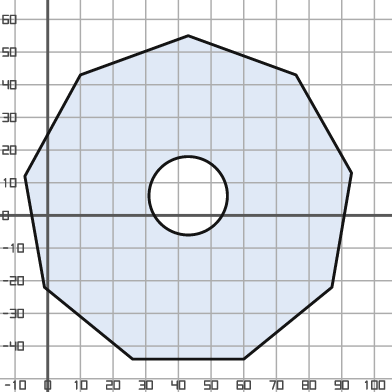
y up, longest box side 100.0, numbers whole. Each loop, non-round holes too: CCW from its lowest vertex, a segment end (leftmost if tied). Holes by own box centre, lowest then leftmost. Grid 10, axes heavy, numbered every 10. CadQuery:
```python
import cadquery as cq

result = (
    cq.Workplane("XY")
    .moveTo(26.0, -44.0)
    .lineTo(60.0, -44.0)
    .lineTo(87.0, -22.0)
    .lineTo(93.0, 13.0)
    .lineTo(76.0, 43.0)
    .lineTo(43.0, 55.0)
    .lineTo(10.0, 43.0)
    .lineTo(-7.0, 12.0)
    .lineTo(-1.0, -22.0)
    .close()
    .moveTo(43.0, 6.0)
    .circle(12.0)
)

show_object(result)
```